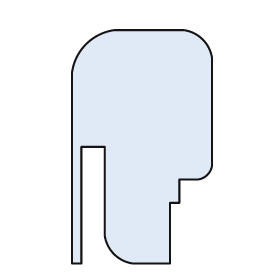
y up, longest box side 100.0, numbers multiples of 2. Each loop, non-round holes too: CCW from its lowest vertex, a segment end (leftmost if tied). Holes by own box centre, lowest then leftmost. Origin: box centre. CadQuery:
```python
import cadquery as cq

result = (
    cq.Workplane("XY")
    .moveTo(-30.0, -50.0)
    .lineTo(-26.0, -50.0)
    .lineTo(-26.0, 0.0)
    .lineTo(-16.0, 0.0)
    .lineTo(-16.0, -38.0)
    .threePointArc((-12.0, -46.0), (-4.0, -50.0))
    .lineTo(12.0, -50.0)
    .lineTo(12.0, -24.0)
    .lineTo(16.0, -24.0)
    .lineTo(16.0, -14.0)
    .lineTo(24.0, -14.0)
    .threePointArc((28.0, -12.0), (30.0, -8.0))
    .lineTo(30.0, 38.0)
    .threePointArc((26.0, 46.0), (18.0, 50.0))
    .lineTo(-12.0, 50.0)
    .threePointArc((-24.0, 44.0), (-30.0, 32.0))
    .close()
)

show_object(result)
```